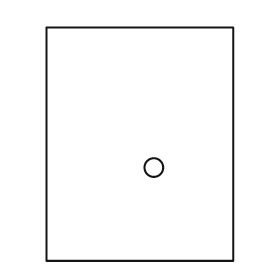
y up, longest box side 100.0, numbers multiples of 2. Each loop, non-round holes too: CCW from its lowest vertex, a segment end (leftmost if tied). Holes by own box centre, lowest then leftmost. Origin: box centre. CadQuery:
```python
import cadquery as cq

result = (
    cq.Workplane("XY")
    .moveTo(-40.0, -50.0)
    .lineTo(40.0, -50.0)
    .lineTo(40.0, 50.0)
    .lineTo(-40.0, 50.0)
    .close()
    .moveTo(6.0, -10.0)
    .circle(4.0)
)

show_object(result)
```